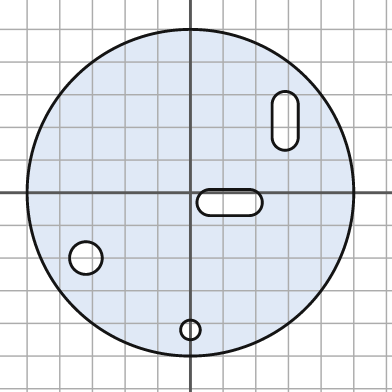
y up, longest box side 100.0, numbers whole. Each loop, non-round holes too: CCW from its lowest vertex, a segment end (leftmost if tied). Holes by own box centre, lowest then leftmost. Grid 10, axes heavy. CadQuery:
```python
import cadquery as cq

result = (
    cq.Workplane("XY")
    .moveTo(0.0, 0.0)
    .circle(50.0)
    .moveTo(0.0, -42.0)
    .circle(3.0)
    .moveTo(-32.0, -20.0)
    .circle(5.0)
    .moveTo(6.0, -7.0)
    .lineTo(18.0, -7.0)
    .threePointArc((22.0, -3.0), (18.0, 1.0))
    .lineTo(6.0, 1.0)
    .threePointArc((2.0, -3.0), (6.0, -7.0))
    .close()
    .moveTo(25.0, 17.0)
    .threePointArc((29.0, 13.0), (33.0, 17.0))
    .lineTo(33.0, 27.0)
    .threePointArc((29.0, 31.0), (25.0, 27.0))
    .close()
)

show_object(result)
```